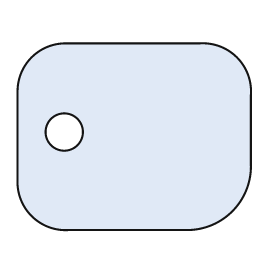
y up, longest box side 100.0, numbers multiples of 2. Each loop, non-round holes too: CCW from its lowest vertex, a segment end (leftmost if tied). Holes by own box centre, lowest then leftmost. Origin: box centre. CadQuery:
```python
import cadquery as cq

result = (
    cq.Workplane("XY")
    .moveTo(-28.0, -40.0)
    .lineTo(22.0, -40.0)
    .threePointArc((42.0, -32.0), (50.0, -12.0))
    .lineTo(50.0, 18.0)
    .threePointArc((44.0, 34.0), (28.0, 40.0))
    .lineTo(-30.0, 40.0)
    .threePointArc((-44.0, 34.0), (-50.0, 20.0))
    .lineTo(-50.0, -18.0)
    .threePointArc((-44.0, -34.0), (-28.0, -40.0))
    .close()
    .moveTo(-30.0, 2.0)
    .circle(8.0)
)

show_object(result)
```